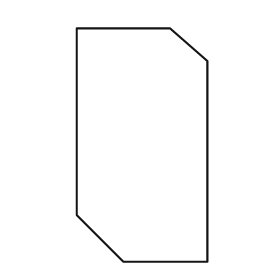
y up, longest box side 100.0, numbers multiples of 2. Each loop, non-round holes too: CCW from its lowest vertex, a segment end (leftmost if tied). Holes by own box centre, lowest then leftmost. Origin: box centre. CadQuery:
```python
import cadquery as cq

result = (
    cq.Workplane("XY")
    .moveTo(-8.0, -50.0)
    .lineTo(28.0, -50.0)
    .lineTo(28.0, 36.0)
    .lineTo(12.0, 50.0)
    .lineTo(-28.0, 50.0)
    .lineTo(-28.0, -30.0)
    .close()
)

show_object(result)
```